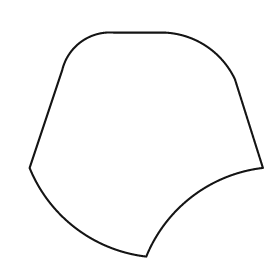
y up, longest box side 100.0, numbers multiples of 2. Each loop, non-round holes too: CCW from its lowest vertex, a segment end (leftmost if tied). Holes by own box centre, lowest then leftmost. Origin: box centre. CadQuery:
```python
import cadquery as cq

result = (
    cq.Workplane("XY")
    .moveTo(0.0, -48.0)
    .threePointArc((20.0, -22.0), (50.0, -10.0))
    .lineTo(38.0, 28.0)
    .threePointArc((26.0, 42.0), (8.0, 48.0))
    .lineTo(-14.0, 48.0)
    .threePointArc((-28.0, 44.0), (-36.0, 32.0))
    .lineTo(-50.0, -10.0)
    .threePointArc((-30.0, -36.0), (0.0, -48.0))
    .close()
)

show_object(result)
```